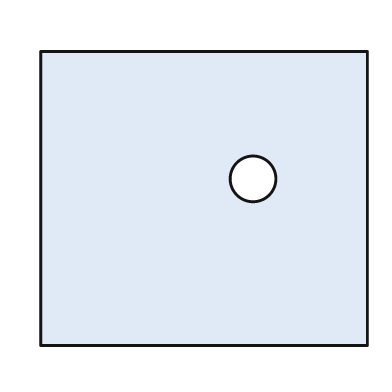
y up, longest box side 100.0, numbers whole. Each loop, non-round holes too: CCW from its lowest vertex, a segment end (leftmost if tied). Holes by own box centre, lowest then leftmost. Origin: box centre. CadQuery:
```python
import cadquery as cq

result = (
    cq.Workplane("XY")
    .moveTo(-50.0, -45.0)
    .lineTo(50.0, -45.0)
    .lineTo(50.0, 45.0)
    .lineTo(-50.0, 45.0)
    .close()
    .moveTo(15.0, 6.0)
    .circle(7.0)
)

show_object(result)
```